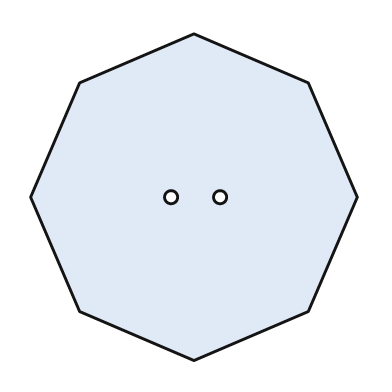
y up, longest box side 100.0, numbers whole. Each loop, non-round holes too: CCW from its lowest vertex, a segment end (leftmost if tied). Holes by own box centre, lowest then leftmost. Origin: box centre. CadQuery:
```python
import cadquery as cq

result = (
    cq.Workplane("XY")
    .moveTo(0.0, -50.0)
    .lineTo(35.0, -35.0)
    .lineTo(50.0, 0.0)
    .lineTo(35.0, 35.0)
    .lineTo(0.0, 50.0)
    .lineTo(-35.0, 35.0)
    .lineTo(-50.0, 0.0)
    .lineTo(-35.0, -35.0)
    .close()
    .moveTo(-7.0, 0.0)
    .circle(2.0)
    .moveTo(8.0, 0.0)
    .circle(2.0)
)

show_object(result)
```